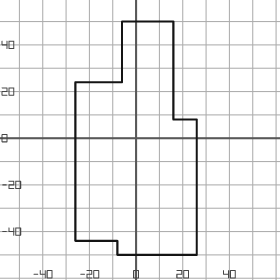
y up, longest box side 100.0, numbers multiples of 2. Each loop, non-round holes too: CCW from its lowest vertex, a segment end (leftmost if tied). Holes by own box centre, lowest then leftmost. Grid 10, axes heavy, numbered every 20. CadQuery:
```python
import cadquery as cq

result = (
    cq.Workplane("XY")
    .moveTo(-8.0, -50.0)
    .lineTo(26.0, -50.0)
    .lineTo(26.0, 8.0)
    .lineTo(16.0, 8.0)
    .lineTo(16.0, 50.0)
    .lineTo(-6.0, 50.0)
    .lineTo(-6.0, 24.0)
    .lineTo(-26.0, 24.0)
    .lineTo(-26.0, -44.0)
    .lineTo(-8.0, -44.0)
    .close()
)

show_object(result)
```